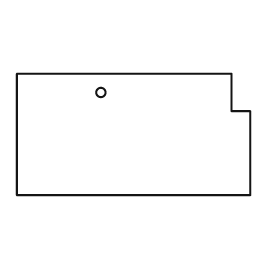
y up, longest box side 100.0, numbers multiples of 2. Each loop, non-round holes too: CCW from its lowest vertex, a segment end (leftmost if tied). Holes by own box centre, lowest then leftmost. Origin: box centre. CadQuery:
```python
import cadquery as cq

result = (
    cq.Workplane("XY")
    .moveTo(-50.0, -26.0)
    .lineTo(50.0, -26.0)
    .lineTo(50.0, 10.0)
    .lineTo(42.0, 10.0)
    .lineTo(42.0, 26.0)
    .lineTo(-50.0, 26.0)
    .close()
    .moveTo(-14.0, 18.0)
    .circle(2.0)
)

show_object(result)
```